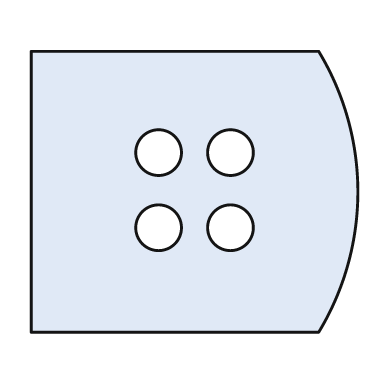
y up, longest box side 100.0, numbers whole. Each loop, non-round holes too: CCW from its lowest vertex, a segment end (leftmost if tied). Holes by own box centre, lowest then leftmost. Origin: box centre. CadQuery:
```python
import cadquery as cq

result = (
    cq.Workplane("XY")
    .moveTo(-50.0, -43.0)
    .lineTo(38.0, -43.0)
    .threePointArc((50.0, 0.0), (38.0, 43.0))
    .lineTo(-50.0, 43.0)
    .close()
    .moveTo(-11.0, -11.0)
    .circle(7.0)
    .moveTo(11.0, -11.0)
    .circle(7.0)
    .moveTo(-11.0, 12.0)
    .circle(7.0)
    .moveTo(11.0, 12.0)
    .circle(7.0)
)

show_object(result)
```